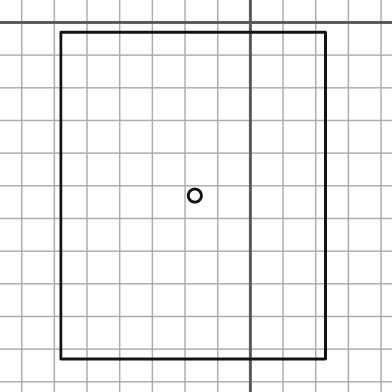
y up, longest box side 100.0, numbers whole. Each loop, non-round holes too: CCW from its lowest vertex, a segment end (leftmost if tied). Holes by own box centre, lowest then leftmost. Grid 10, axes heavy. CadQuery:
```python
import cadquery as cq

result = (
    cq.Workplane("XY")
    .moveTo(-58.0, -103.0)
    .lineTo(23.0, -103.0)
    .lineTo(23.0, -3.0)
    .lineTo(-58.0, -3.0)
    .close()
    .moveTo(-17.0, -53.0)
    .circle(2.0)
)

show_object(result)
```